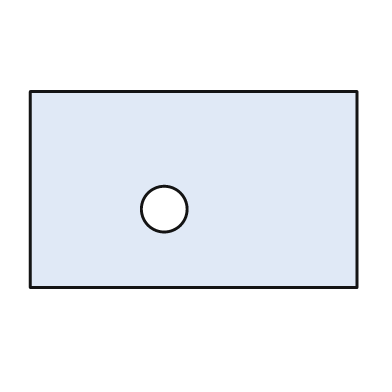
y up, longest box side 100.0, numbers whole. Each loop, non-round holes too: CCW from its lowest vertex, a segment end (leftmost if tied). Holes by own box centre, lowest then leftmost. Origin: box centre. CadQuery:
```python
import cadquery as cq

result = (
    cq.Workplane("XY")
    .moveTo(-50.0, -30.0)
    .lineTo(50.0, -30.0)
    .lineTo(50.0, 30.0)
    .lineTo(-50.0, 30.0)
    .close()
    .moveTo(-9.0, -6.0)
    .circle(7.0)
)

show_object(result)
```